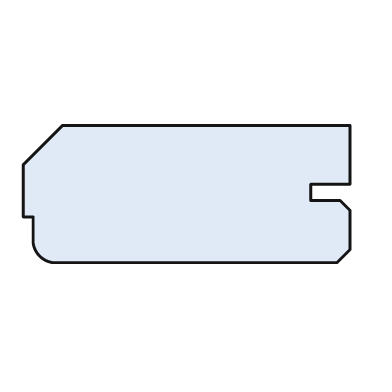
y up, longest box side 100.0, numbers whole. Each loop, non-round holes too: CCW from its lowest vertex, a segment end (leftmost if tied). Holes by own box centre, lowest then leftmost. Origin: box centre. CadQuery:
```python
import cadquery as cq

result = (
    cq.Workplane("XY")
    .moveTo(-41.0, -21.0)
    .lineTo(46.0, -21.0)
    .lineTo(50.0, -17.0)
    .lineTo(50.0, -5.0)
    .lineTo(47.0, -2.0)
    .lineTo(38.0, -2.0)
    .lineTo(38.0, 3.0)
    .lineTo(50.0, 3.0)
    .lineTo(50.0, 21.0)
    .lineTo(-38.0, 21.0)
    .lineTo(-50.0, 9.0)
    .lineTo(-50.0, -7.0)
    .lineTo(-47.0, -7.0)
    .lineTo(-47.0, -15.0)
    .threePointArc((-45.0, -19.0), (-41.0, -21.0))
    .close()
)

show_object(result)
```